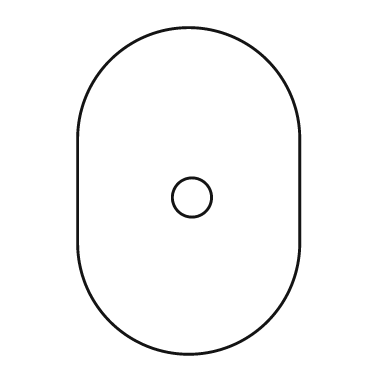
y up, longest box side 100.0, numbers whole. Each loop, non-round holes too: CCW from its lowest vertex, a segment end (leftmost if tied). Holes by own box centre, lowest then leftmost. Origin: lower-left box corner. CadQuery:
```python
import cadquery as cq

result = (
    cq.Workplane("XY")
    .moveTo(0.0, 34.0)
    .threePointArc((34.0, 0.0), (68.0, 34.0))
    .lineTo(68.0, 66.0)
    .threePointArc((34.0, 100.0), (0.0, 66.0))
    .close()
    .moveTo(35.0, 48.0)
    .circle(6.0)
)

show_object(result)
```